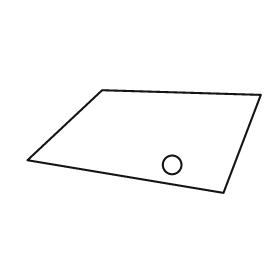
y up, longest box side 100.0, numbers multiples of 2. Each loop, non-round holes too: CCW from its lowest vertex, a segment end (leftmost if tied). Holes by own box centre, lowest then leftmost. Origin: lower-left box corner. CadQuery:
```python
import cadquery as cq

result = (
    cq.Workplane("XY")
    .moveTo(84.0, 0.0)
    .lineTo(100.0, 42.0)
    .lineTo(32.0, 44.0)
    .lineTo(0.0, 14.0)
    .close()
    .moveTo(62.0, 12.0)
    .circle(4.0)
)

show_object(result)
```